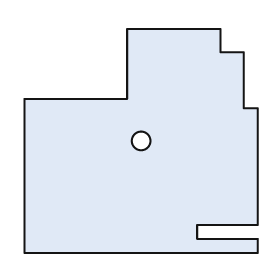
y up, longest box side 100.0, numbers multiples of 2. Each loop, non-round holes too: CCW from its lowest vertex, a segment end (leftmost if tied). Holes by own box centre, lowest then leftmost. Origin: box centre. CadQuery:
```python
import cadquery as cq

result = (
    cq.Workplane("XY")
    .moveTo(-50.0, -48.0)
    .lineTo(50.0, -48.0)
    .lineTo(50.0, -42.0)
    .lineTo(24.0, -42.0)
    .lineTo(24.0, -36.0)
    .lineTo(50.0, -36.0)
    .lineTo(50.0, 14.0)
    .lineTo(44.0, 14.0)
    .lineTo(44.0, 38.0)
    .lineTo(34.0, 38.0)
    .lineTo(34.0, 48.0)
    .lineTo(-6.0, 48.0)
    .lineTo(-6.0, 18.0)
    .lineTo(-50.0, 18.0)
    .close()
    .moveTo(0.0, 0.0)
    .circle(4.0)
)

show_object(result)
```